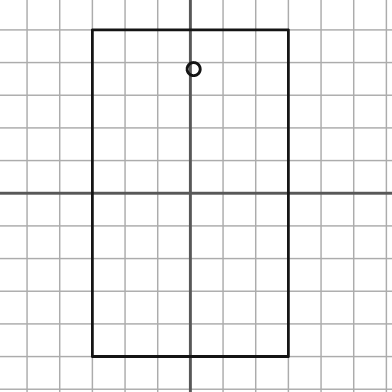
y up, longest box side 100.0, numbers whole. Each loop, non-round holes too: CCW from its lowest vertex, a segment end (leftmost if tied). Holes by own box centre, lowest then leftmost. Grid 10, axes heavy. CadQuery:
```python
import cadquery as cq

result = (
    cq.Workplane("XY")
    .moveTo(-30.0, -50.0)
    .lineTo(30.0, -50.0)
    .lineTo(30.0, 50.0)
    .lineTo(-30.0, 50.0)
    .close()
    .moveTo(1.0, 38.0)
    .circle(2.0)
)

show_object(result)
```